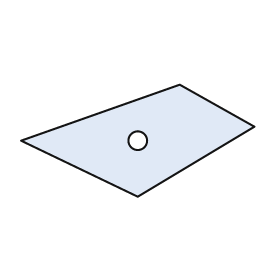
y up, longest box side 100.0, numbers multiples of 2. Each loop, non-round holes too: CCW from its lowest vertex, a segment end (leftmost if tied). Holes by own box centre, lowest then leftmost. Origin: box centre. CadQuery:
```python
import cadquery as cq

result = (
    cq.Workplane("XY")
    .moveTo(0.0, -24.0)
    .lineTo(50.0, 6.0)
    .lineTo(18.0, 24.0)
    .lineTo(-50.0, 0.0)
    .close()
    .moveTo(0.0, 0.0)
    .circle(4.0)
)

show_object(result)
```